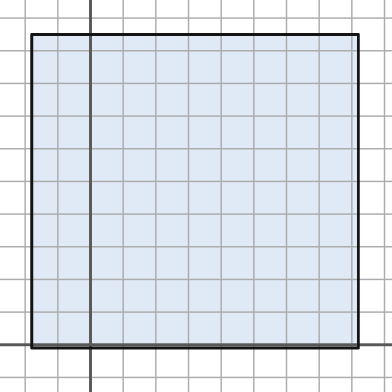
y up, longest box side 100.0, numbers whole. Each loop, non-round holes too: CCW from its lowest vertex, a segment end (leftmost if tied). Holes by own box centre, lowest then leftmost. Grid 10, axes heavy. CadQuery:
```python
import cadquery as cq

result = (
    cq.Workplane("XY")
    .moveTo(-18.0, -1.0)
    .lineTo(82.0, -1.0)
    .lineTo(82.0, 95.0)
    .lineTo(-18.0, 95.0)
    .close()
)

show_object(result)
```